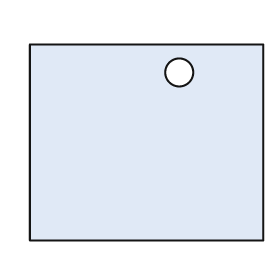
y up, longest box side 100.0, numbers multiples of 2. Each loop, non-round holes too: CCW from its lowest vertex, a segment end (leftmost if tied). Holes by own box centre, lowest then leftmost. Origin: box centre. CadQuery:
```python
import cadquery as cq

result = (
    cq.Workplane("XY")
    .moveTo(-50.0, -42.0)
    .lineTo(50.0, -42.0)
    .lineTo(50.0, 42.0)
    .lineTo(-50.0, 42.0)
    .close()
    .moveTo(14.0, 30.0)
    .circle(6.0)
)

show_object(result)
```